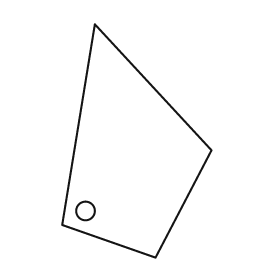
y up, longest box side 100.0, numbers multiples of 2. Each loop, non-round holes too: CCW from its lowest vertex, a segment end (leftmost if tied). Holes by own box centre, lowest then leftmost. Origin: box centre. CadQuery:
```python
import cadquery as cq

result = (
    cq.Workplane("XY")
    .moveTo(8.0, -50.0)
    .lineTo(32.0, -4.0)
    .lineTo(-18.0, 50.0)
    .lineTo(-32.0, -36.0)
    .close()
    .moveTo(-22.0, -30.0)
    .circle(4.0)
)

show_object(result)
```